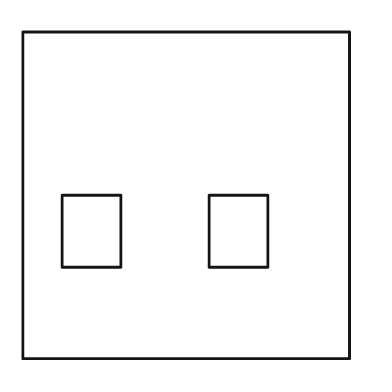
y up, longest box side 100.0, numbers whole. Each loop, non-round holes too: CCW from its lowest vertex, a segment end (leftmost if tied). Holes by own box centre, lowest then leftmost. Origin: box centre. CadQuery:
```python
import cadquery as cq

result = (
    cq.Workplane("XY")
    .moveTo(-50.0, -50.0)
    .lineTo(50.0, -50.0)
    .lineTo(50.0, 50.0)
    .lineTo(-50.0, 50.0)
    .close()
    .moveTo(-38.0, -22.0)
    .lineTo(-20.0, -22.0)
    .lineTo(-20.0, 0.0)
    .lineTo(-38.0, 0.0)
    .close()
    .moveTo(7.0, -22.0)
    .lineTo(25.0, -22.0)
    .lineTo(25.0, 0.0)
    .lineTo(7.0, 0.0)
    .close()
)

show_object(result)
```